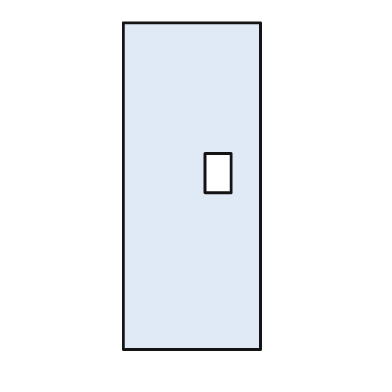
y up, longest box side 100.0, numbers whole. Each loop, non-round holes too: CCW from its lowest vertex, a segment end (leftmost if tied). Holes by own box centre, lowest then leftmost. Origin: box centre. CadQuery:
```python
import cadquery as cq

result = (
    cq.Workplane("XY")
    .moveTo(-21.0, -50.0)
    .lineTo(21.0, -50.0)
    .lineTo(21.0, 50.0)
    .lineTo(-21.0, 50.0)
    .close()
    .moveTo(4.0, -2.0)
    .lineTo(12.0, -2.0)
    .lineTo(12.0, 10.0)
    .lineTo(4.0, 10.0)
    .close()
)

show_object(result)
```